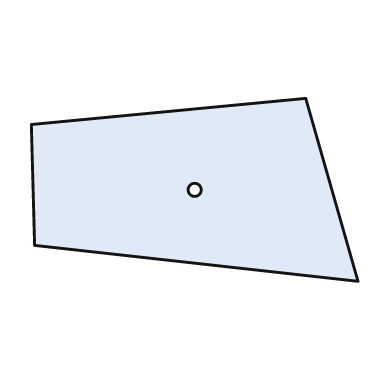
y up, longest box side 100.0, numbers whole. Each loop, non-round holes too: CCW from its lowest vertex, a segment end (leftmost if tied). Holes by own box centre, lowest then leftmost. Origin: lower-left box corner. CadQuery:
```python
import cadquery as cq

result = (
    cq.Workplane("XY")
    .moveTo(100.0, 0.0)
    .lineTo(84.0, 56.0)
    .lineTo(0.0, 48.0)
    .lineTo(1.0, 11.0)
    .close()
    .moveTo(50.0, 28.0)
    .circle(2.0)
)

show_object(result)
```